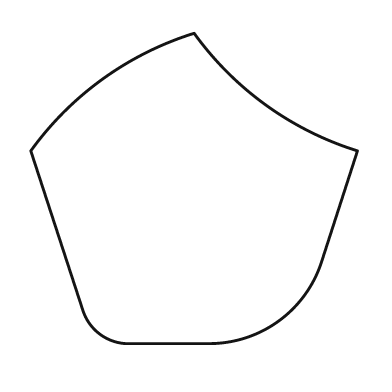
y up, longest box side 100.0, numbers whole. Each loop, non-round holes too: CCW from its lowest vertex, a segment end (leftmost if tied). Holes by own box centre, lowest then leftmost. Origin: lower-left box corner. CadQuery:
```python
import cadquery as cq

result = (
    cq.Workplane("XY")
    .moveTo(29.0, 0.0)
    .lineTo(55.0, 0.0)
    .threePointArc((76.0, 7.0), (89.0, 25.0))
    .lineTo(100.0, 59.0)
    .threePointArc((72.0, 73.0), (50.0, 95.0))
    .threePointArc((22.0, 81.0), (0.0, 59.0))
    .lineTo(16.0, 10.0)
    .threePointArc((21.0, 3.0), (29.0, 0.0))
    .close()
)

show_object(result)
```